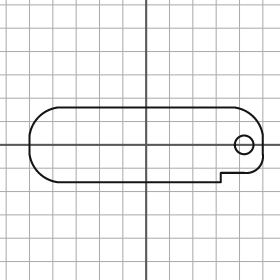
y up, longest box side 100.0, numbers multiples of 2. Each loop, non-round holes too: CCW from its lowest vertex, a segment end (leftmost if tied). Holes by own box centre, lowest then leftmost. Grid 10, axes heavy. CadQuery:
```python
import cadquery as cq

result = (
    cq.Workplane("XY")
    .moveTo(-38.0, -16.0)
    .lineTo(32.0, -16.0)
    .lineTo(32.0, -12.0)
    .lineTo(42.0, -12.0)
    .threePointArc((48.0, -10.0), (50.0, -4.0))
    .lineTo(50.0, 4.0)
    .threePointArc((46.0, 12.0), (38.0, 16.0))
    .lineTo(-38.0, 16.0)
    .threePointArc((-46.0, 12.0), (-50.0, 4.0))
    .lineTo(-50.0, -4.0)
    .threePointArc((-46.0, -12.0), (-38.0, -16.0))
    .close()
    .moveTo(42.0, 0.0)
    .circle(4.0)
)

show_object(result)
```